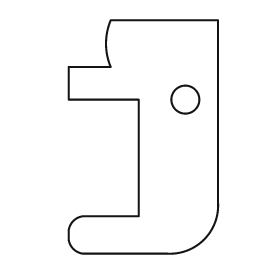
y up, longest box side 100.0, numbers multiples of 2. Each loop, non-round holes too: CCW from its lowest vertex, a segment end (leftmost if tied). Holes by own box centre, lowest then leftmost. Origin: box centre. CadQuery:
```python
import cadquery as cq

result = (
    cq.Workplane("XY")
    .moveTo(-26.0, -50.0)
    .lineTo(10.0, -50.0)
    .threePointArc((26.0, -44.0), (32.0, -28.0))
    .lineTo(32.0, 50.0)
    .lineTo(-14.0, 50.0)
    .threePointArc((-16.0, 40.0), (-14.0, 30.0))
    .lineTo(-32.0, 30.0)
    .lineTo(-32.0, 16.0)
    .lineTo(-2.0, 16.0)
    .lineTo(-2.0, -34.0)
    .lineTo(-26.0, -34.0)
    .threePointArc((-30.0, -36.0), (-32.0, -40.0))
    .lineTo(-32.0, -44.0)
    .threePointArc((-30.0, -48.0), (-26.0, -50.0))
    .close()
    .moveTo(18.0, 16.0)
    .circle(6.0)
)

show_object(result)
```